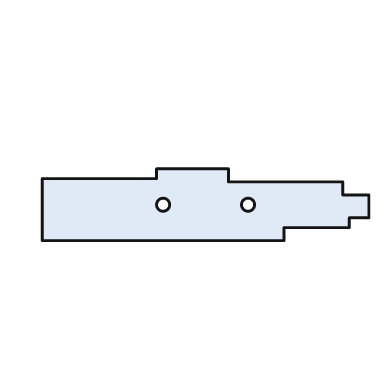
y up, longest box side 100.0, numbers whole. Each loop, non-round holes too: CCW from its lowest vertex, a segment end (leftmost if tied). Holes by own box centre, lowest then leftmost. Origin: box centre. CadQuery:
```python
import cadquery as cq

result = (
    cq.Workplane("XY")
    .moveTo(-50.0, -11.0)
    .lineTo(24.0, -11.0)
    .lineTo(24.0, -7.0)
    .lineTo(44.0, -7.0)
    .lineTo(44.0, -4.0)
    .lineTo(50.0, -4.0)
    .lineTo(50.0, 3.0)
    .lineTo(42.0, 3.0)
    .lineTo(42.0, 7.0)
    .lineTo(7.0, 7.0)
    .lineTo(7.0, 11.0)
    .lineTo(-15.0, 11.0)
    .lineTo(-15.0, 8.0)
    .lineTo(-50.0, 8.0)
    .close()
    .moveTo(-13.0, 0.0)
    .circle(2.0)
    .moveTo(13.0, 0.0)
    .circle(2.0)
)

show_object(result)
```